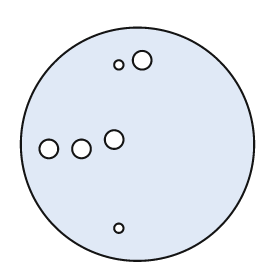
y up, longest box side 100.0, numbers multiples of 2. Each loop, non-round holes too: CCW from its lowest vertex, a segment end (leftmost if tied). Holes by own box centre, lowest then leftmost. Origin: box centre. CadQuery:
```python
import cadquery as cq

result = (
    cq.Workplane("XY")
    .moveTo(0.0, 0.0)
    .circle(50.0)
    .moveTo(-8.0, -36.0)
    .circle(2.0)
    .moveTo(-38.0, -2.0)
    .circle(4.0)
    .moveTo(-24.0, -2.0)
    .circle(4.0)
    .moveTo(-10.0, 2.0)
    .circle(4.0)
    .moveTo(-8.0, 34.0)
    .circle(2.0)
    .moveTo(2.0, 36.0)
    .circle(4.0)
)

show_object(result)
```